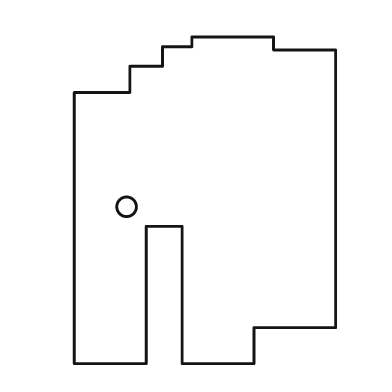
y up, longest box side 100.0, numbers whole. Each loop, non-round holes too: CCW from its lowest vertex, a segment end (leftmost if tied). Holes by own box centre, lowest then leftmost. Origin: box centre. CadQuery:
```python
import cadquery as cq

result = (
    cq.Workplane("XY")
    .moveTo(-40.0, -50.0)
    .lineTo(-18.0, -50.0)
    .lineTo(-18.0, -8.0)
    .lineTo(-7.0, -8.0)
    .lineTo(-7.0, -50.0)
    .lineTo(15.0, -50.0)
    .lineTo(15.0, -39.0)
    .lineTo(40.0, -39.0)
    .lineTo(40.0, 46.0)
    .lineTo(21.0, 46.0)
    .lineTo(21.0, 50.0)
    .lineTo(-4.0, 50.0)
    .lineTo(-4.0, 47.0)
    .lineTo(-13.0, 47.0)
    .lineTo(-13.0, 41.0)
    .lineTo(-23.0, 41.0)
    .lineTo(-23.0, 33.0)
    .lineTo(-40.0, 33.0)
    .close()
    .moveTo(-24.0, -2.0)
    .circle(3.0)
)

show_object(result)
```